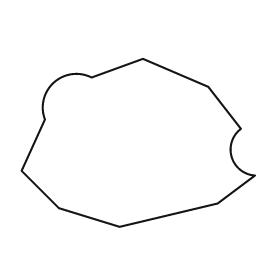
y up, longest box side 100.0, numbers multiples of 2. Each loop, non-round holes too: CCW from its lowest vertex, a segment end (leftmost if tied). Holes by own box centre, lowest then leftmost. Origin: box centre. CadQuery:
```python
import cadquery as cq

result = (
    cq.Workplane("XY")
    .moveTo(-8.0, -36.0)
    .lineTo(34.0, -26.0)
    .lineTo(50.0, -14.0)
    .threePointArc((40.0, -6.0), (44.0, 6.0))
    .lineTo(30.0, 24.0)
    .lineTo(2.0, 36.0)
    .lineTo(-20.0, 28.0)
    .threePointArc((-36.0, 26.0), (-40.0, 10.0))
    .lineTo(-50.0, -12.0)
    .lineTo(-34.0, -28.0)
    .close()
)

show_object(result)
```